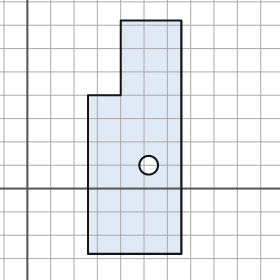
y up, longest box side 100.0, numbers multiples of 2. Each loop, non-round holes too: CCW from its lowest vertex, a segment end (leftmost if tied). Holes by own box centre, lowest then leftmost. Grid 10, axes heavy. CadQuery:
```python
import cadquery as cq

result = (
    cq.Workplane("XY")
    .moveTo(26.0, -28.0)
    .lineTo(66.0, -28.0)
    .lineTo(66.0, 72.0)
    .lineTo(40.0, 72.0)
    .lineTo(40.0, 40.0)
    .lineTo(26.0, 40.0)
    .close()
    .moveTo(52.0, 10.0)
    .circle(4.0)
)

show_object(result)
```